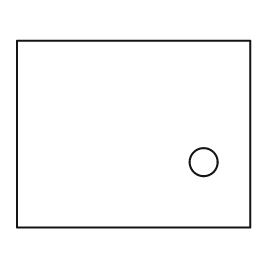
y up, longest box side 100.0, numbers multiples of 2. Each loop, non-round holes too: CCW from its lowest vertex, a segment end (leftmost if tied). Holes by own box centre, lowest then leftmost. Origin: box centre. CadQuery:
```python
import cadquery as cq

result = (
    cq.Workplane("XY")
    .moveTo(-50.0, -40.0)
    .lineTo(50.0, -40.0)
    .lineTo(50.0, 40.0)
    .lineTo(-50.0, 40.0)
    .close()
    .moveTo(30.0, -12.0)
    .circle(6.0)
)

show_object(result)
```